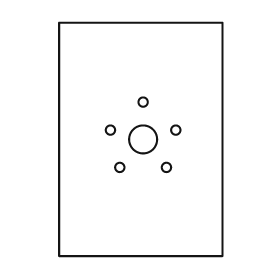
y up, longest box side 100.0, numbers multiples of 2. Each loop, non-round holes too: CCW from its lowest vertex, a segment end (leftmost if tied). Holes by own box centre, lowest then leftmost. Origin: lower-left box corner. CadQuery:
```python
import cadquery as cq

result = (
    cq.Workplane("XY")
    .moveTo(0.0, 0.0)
    .lineTo(70.0, 0.0)
    .lineTo(70.0, 100.0)
    .lineTo(0.0, 100.0)
    .close()
    .moveTo(26.0, 38.0)
    .circle(2.0)
    .moveTo(46.0, 38.0)
    .circle(2.0)
    .moveTo(36.0, 50.0)
    .circle(6.0)
    .moveTo(22.0, 54.0)
    .circle(2.0)
    .moveTo(50.0, 54.0)
    .circle(2.0)
    .moveTo(36.0, 66.0)
    .circle(2.0)
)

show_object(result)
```